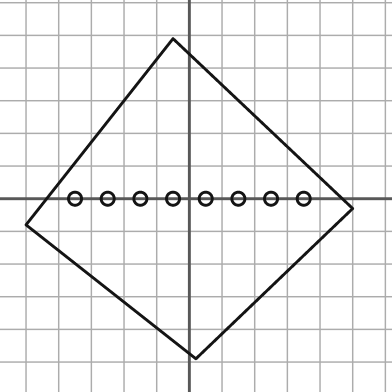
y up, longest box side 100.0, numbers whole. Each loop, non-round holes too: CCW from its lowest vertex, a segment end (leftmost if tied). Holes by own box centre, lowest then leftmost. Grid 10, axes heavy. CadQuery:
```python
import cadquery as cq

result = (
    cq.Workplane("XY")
    .moveTo(2.0, -49.0)
    .lineTo(50.0, -3.0)
    .lineTo(-5.0, 49.0)
    .lineTo(-50.0, -8.0)
    .close()
    .moveTo(-35.0, 0.0)
    .circle(2.0)
    .moveTo(-25.0, 0.0)
    .circle(2.0)
    .moveTo(-15.0, 0.0)
    .circle(2.0)
    .moveTo(-5.0, 0.0)
    .circle(2.0)
    .moveTo(5.0, 0.0)
    .circle(2.0)
    .moveTo(15.0, 0.0)
    .circle(2.0)
    .moveTo(25.0, 0.0)
    .circle(2.0)
    .moveTo(35.0, 0.0)
    .circle(2.0)
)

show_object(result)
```